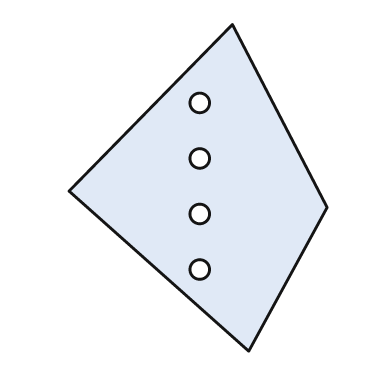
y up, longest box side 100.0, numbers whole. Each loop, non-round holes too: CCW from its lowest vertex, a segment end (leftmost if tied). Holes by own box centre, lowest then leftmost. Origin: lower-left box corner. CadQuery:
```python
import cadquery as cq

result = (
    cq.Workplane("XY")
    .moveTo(55.0, 0.0)
    .lineTo(79.0, 44.0)
    .lineTo(50.0, 100.0)
    .lineTo(0.0, 49.0)
    .close()
    .moveTo(40.0, 25.0)
    .circle(3.0)
    .moveTo(40.0, 42.0)
    .circle(3.0)
    .moveTo(40.0, 59.0)
    .circle(3.0)
    .moveTo(40.0, 76.0)
    .circle(3.0)
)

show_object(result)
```